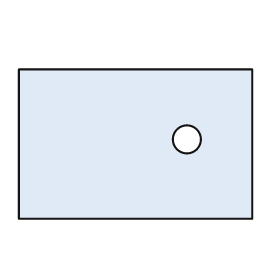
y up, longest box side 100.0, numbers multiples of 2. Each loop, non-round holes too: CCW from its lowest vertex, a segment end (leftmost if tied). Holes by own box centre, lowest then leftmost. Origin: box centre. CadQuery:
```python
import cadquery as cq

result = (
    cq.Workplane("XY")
    .moveTo(-50.0, -32.0)
    .lineTo(50.0, -32.0)
    .lineTo(50.0, 32.0)
    .lineTo(-50.0, 32.0)
    .close()
    .moveTo(22.0, 2.0)
    .circle(6.0)
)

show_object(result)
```